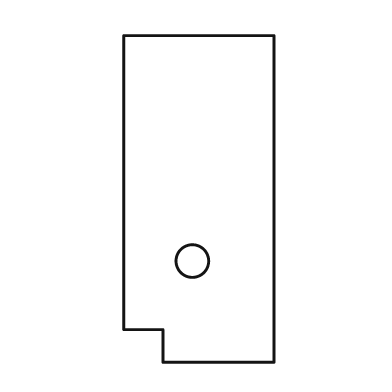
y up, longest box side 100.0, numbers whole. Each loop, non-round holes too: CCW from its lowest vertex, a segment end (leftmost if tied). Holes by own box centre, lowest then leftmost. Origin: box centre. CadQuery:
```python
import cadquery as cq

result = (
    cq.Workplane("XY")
    .moveTo(-11.0, -50.0)
    .lineTo(23.0, -50.0)
    .lineTo(23.0, 50.0)
    .lineTo(-23.0, 50.0)
    .lineTo(-23.0, -40.0)
    .lineTo(-11.0, -40.0)
    .close()
    .moveTo(-2.0, -19.0)
    .circle(5.0)
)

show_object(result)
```